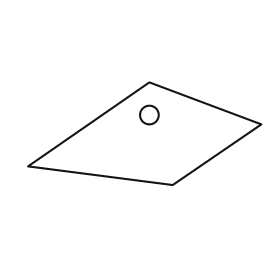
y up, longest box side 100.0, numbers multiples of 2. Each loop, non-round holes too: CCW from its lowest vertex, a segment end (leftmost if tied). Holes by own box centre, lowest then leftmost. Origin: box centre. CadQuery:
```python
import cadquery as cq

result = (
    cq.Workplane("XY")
    .moveTo(12.0, -22.0)
    .lineTo(50.0, 4.0)
    .lineTo(2.0, 22.0)
    .lineTo(-50.0, -14.0)
    .close()
    .moveTo(2.0, 8.0)
    .circle(4.0)
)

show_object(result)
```